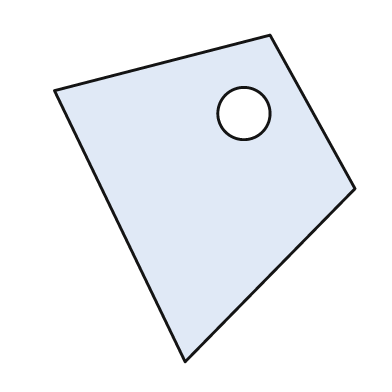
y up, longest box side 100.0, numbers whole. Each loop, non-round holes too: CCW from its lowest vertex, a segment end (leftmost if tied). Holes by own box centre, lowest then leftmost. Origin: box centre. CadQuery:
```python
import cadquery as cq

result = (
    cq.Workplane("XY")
    .moveTo(-6.0, -50.0)
    .lineTo(46.0, 3.0)
    .lineTo(20.0, 50.0)
    .lineTo(-46.0, 33.0)
    .close()
    .moveTo(12.0, 26.0)
    .circle(8.0)
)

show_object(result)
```